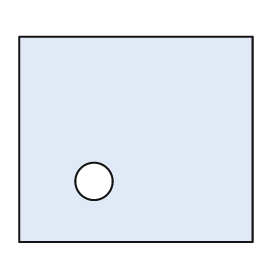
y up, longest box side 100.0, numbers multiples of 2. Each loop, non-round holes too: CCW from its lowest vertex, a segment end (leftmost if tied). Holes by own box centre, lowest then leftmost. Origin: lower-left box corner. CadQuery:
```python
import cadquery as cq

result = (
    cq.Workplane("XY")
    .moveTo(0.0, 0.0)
    .lineTo(100.0, 0.0)
    .lineTo(100.0, 88.0)
    .lineTo(0.0, 88.0)
    .close()
    .moveTo(32.0, 26.0)
    .circle(8.0)
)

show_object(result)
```